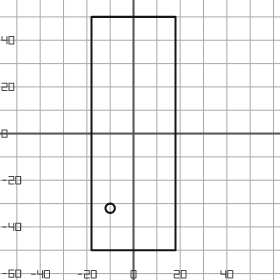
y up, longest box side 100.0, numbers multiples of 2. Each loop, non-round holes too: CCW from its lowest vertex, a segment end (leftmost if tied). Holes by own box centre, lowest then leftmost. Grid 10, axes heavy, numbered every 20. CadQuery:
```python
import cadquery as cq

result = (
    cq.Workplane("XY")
    .moveTo(-18.0, -50.0)
    .lineTo(18.0, -50.0)
    .lineTo(18.0, 50.0)
    .lineTo(-18.0, 50.0)
    .close()
    .moveTo(-10.0, -32.0)
    .circle(2.0)
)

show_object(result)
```